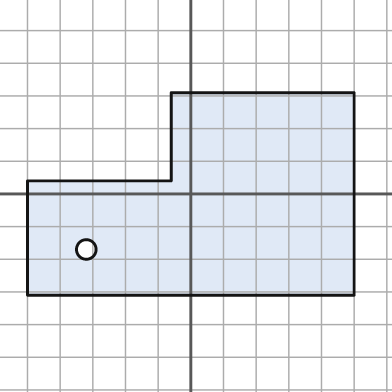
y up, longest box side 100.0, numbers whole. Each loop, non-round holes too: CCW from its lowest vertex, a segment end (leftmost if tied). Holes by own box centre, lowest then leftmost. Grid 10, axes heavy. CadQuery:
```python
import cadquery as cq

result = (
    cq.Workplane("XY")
    .moveTo(-50.0, -31.0)
    .lineTo(50.0, -31.0)
    .lineTo(50.0, 31.0)
    .lineTo(-6.0, 31.0)
    .lineTo(-6.0, 4.0)
    .lineTo(-50.0, 4.0)
    .close()
    .moveTo(-32.0, -17.0)
    .circle(3.0)
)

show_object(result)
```